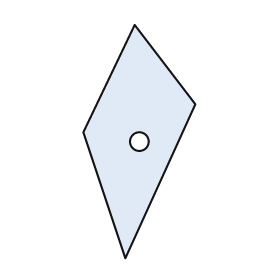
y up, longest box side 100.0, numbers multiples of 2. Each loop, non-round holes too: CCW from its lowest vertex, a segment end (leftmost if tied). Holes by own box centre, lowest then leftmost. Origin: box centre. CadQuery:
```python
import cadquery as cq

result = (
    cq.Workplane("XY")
    .moveTo(-6.0, -50.0)
    .lineTo(24.0, 16.0)
    .lineTo(-2.0, 50.0)
    .lineTo(-24.0, 4.0)
    .close()
    .moveTo(0.0, 0.0)
    .circle(4.0)
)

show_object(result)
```